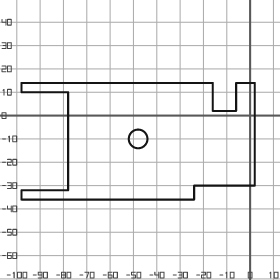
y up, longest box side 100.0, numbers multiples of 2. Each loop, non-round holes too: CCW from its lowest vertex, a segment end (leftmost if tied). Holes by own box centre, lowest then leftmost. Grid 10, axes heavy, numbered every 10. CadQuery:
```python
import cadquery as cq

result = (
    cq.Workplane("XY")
    .moveTo(-98.0, -36.0)
    .lineTo(-24.0, -36.0)
    .lineTo(-24.0, -30.0)
    .lineTo(2.0, -30.0)
    .lineTo(2.0, 14.0)
    .lineTo(-6.0, 14.0)
    .lineTo(-6.0, 2.0)
    .lineTo(-16.0, 2.0)
    .lineTo(-16.0, 14.0)
    .lineTo(-98.0, 14.0)
    .lineTo(-98.0, 10.0)
    .lineTo(-78.0, 10.0)
    .lineTo(-78.0, -32.0)
    .lineTo(-98.0, -32.0)
    .close()
    .moveTo(-48.0, -10.0)
    .circle(4.0)
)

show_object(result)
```